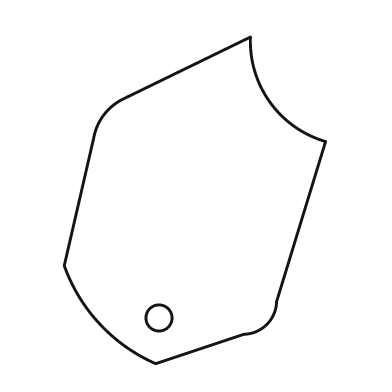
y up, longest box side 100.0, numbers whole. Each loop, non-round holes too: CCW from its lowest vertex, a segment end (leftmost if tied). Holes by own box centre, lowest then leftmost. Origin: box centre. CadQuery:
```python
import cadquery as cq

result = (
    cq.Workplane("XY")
    .moveTo(-12.0, -50.0)
    .lineTo(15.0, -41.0)
    .threePointArc((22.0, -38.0), (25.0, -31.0))
    .lineTo(40.0, 18.0)
    .threePointArc((23.0, 30.0), (17.0, 50.0))
    .lineTo(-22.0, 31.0)
    .threePointArc((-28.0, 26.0), (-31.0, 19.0))
    .lineTo(-40.0, -20.0)
    .threePointArc((-29.0, -38.0), (-12.0, -50.0))
    .close()
    .moveTo(-11.0, -36.0)
    .circle(4.0)
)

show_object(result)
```